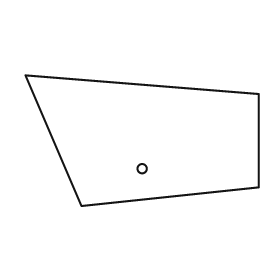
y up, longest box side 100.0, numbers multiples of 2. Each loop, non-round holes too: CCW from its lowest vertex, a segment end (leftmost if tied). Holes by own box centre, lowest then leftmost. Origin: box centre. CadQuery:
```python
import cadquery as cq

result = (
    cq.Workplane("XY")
    .moveTo(-26.0, -28.0)
    .lineTo(50.0, -20.0)
    .lineTo(50.0, 20.0)
    .lineTo(-50.0, 28.0)
    .close()
    .moveTo(0.0, -12.0)
    .circle(2.0)
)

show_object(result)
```